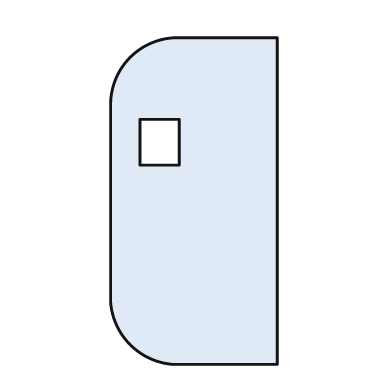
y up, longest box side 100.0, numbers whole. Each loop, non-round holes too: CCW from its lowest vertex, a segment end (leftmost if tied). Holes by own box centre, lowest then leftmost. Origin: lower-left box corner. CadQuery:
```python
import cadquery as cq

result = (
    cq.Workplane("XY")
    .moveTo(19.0, 0.0)
    .lineTo(51.0, 0.0)
    .lineTo(51.0, 100.0)
    .lineTo(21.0, 100.0)
    .threePointArc((6.0, 94.0), (0.0, 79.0))
    .lineTo(0.0, 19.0)
    .threePointArc((6.0, 6.0), (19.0, 0.0))
    .close()
    .moveTo(9.0, 61.0)
    .lineTo(21.0, 61.0)
    .lineTo(21.0, 75.0)
    .lineTo(9.0, 75.0)
    .close()
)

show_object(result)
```